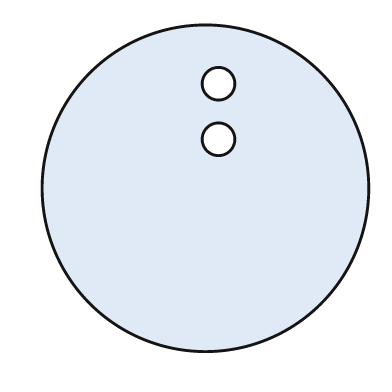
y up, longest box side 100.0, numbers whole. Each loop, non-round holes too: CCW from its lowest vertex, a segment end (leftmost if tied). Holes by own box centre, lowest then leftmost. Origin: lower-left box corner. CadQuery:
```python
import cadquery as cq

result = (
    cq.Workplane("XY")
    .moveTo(50.0, 50.0)
    .circle(50.0)
    .moveTo(54.0, 65.0)
    .circle(5.0)
    .moveTo(54.0, 82.0)
    .circle(5.0)
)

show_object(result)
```